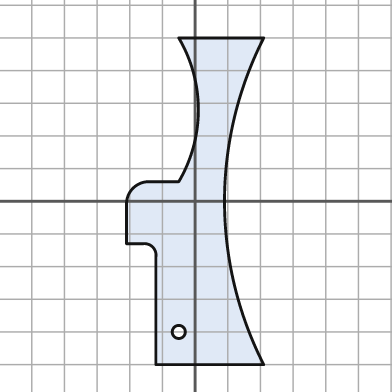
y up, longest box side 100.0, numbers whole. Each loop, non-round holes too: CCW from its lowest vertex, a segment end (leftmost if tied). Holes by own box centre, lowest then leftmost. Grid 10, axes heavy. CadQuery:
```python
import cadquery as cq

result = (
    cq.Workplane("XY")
    .moveTo(-12.0, -50.0)
    .lineTo(21.0, -50.0)
    .threePointArc((9.0, 0.0), (21.0, 50.0))
    .lineTo(-5.0, 50.0)
    .threePointArc((1.0, 28.0), (-5.0, 6.0))
    .lineTo(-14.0, 6.0)
    .threePointArc((-19.0, 4.0), (-21.0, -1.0))
    .lineTo(-21.0, -13.0)
    .lineTo(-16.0, -13.0)
    .threePointArc((-13.0, -14.0), (-12.0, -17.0))
    .close()
    .moveTo(-5.0, -40.0)
    .circle(2.0)
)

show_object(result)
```